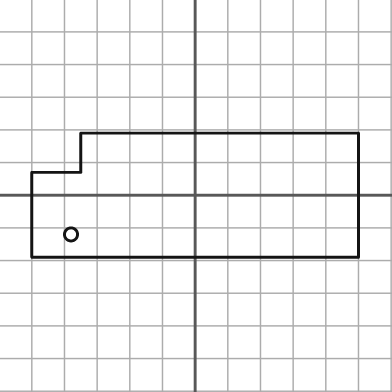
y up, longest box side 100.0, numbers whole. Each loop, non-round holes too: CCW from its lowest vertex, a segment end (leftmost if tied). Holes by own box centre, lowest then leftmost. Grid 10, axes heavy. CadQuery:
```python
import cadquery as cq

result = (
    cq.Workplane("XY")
    .moveTo(-50.0, -19.0)
    .lineTo(50.0, -19.0)
    .lineTo(50.0, 19.0)
    .lineTo(-35.0, 19.0)
    .lineTo(-35.0, 7.0)
    .lineTo(-50.0, 7.0)
    .close()
    .moveTo(-38.0, -12.0)
    .circle(2.0)
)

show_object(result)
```